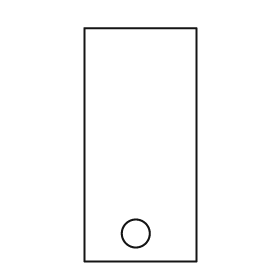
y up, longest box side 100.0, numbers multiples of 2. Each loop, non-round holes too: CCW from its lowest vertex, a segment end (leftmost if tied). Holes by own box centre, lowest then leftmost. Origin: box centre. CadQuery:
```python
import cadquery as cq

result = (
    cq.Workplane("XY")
    .moveTo(-24.0, -50.0)
    .lineTo(24.0, -50.0)
    .lineTo(24.0, 50.0)
    .lineTo(-24.0, 50.0)
    .close()
    .moveTo(-2.0, -38.0)
    .circle(6.0)
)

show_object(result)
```